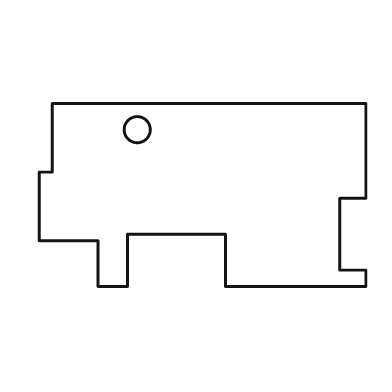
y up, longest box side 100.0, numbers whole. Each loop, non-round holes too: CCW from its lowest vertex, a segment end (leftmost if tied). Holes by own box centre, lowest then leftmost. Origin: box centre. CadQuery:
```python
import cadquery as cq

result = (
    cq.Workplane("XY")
    .moveTo(-32.0, -28.0)
    .lineTo(-23.0, -28.0)
    .lineTo(-23.0, -12.0)
    .lineTo(7.0, -12.0)
    .lineTo(7.0, -28.0)
    .lineTo(50.0, -28.0)
    .lineTo(50.0, -23.0)
    .lineTo(42.0, -23.0)
    .lineTo(42.0, -1.0)
    .lineTo(50.0, -1.0)
    .lineTo(50.0, 28.0)
    .lineTo(-46.0, 28.0)
    .lineTo(-46.0, 7.0)
    .lineTo(-50.0, 7.0)
    .lineTo(-50.0, -14.0)
    .lineTo(-32.0, -14.0)
    .close()
    .moveTo(-20.0, 20.0)
    .circle(4.0)
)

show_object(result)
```